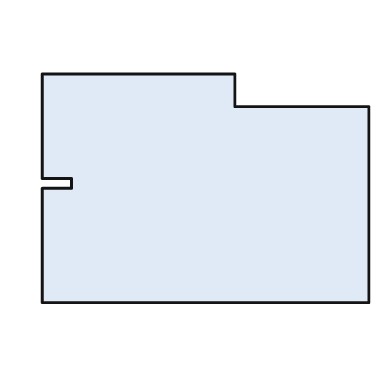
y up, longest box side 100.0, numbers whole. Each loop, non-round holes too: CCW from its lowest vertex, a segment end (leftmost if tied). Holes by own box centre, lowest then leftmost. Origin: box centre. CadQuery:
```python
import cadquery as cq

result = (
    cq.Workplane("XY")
    .moveTo(-50.0, -35.0)
    .lineTo(50.0, -35.0)
    .lineTo(50.0, 25.0)
    .lineTo(9.0, 25.0)
    .lineTo(9.0, 35.0)
    .lineTo(-50.0, 35.0)
    .lineTo(-50.0, 3.0)
    .lineTo(-41.0, 3.0)
    .lineTo(-41.0, 0.0)
    .lineTo(-50.0, 0.0)
    .close()
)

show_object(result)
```